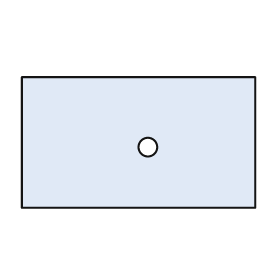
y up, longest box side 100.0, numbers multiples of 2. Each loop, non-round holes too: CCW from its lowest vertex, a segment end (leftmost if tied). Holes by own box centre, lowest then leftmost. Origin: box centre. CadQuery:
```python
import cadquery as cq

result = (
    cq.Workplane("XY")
    .moveTo(-50.0, -28.0)
    .lineTo(50.0, -28.0)
    .lineTo(50.0, 28.0)
    .lineTo(-50.0, 28.0)
    .close()
    .moveTo(4.0, -2.0)
    .circle(4.0)
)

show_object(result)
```